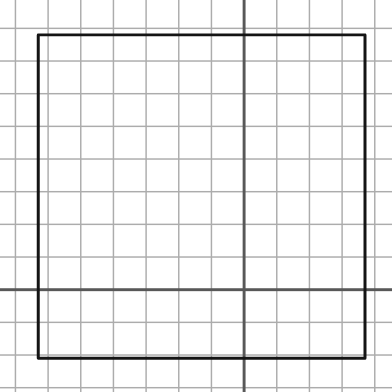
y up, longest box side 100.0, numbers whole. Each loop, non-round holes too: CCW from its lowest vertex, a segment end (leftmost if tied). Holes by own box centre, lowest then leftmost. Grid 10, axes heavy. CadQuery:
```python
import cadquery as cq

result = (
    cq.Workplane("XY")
    .moveTo(-63.0, -21.0)
    .lineTo(37.0, -21.0)
    .lineTo(37.0, 78.0)
    .lineTo(-63.0, 78.0)
    .close()
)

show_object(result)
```